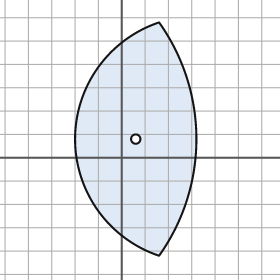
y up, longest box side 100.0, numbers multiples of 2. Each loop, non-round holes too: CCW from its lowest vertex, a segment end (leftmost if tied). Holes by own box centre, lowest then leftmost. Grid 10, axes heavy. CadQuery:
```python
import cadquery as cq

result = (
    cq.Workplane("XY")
    .moveTo(16.0, -42.0)
    .threePointArc((32.0, 8.0), (16.0, 58.0))
    .threePointArc((-20.0, 8.0), (16.0, -42.0))
    .close()
    .moveTo(6.0, 8.0)
    .circle(2.0)
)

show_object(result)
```